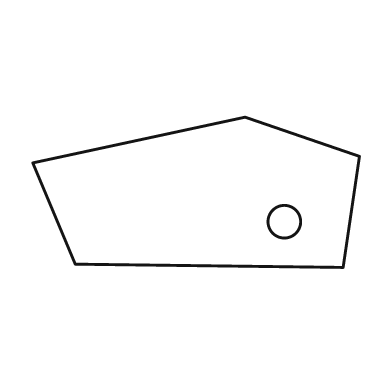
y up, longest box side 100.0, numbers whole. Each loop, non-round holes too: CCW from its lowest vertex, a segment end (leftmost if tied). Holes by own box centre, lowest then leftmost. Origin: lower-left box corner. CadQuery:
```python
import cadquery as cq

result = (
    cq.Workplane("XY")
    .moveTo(95.0, 0.0)
    .lineTo(100.0, 34.0)
    .lineTo(65.0, 46.0)
    .lineTo(0.0, 32.0)
    .lineTo(13.0, 1.0)
    .close()
    .moveTo(77.0, 14.0)
    .circle(5.0)
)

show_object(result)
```